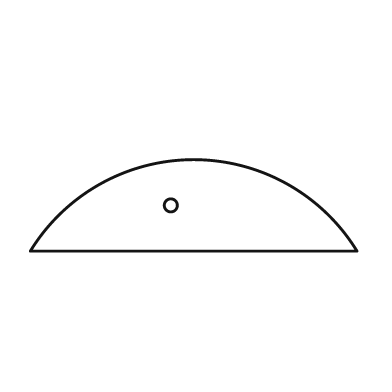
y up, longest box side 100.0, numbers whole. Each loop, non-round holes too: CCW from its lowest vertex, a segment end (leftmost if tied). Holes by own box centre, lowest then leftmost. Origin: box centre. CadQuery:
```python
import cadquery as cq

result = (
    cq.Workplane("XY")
    .moveTo(-50.0, -14.0)
    .lineTo(50.0, -14.0)
    .threePointArc((0.0, 14.0), (-50.0, -14.0))
    .close()
    .moveTo(-7.0, 0.0)
    .circle(2.0)
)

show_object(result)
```